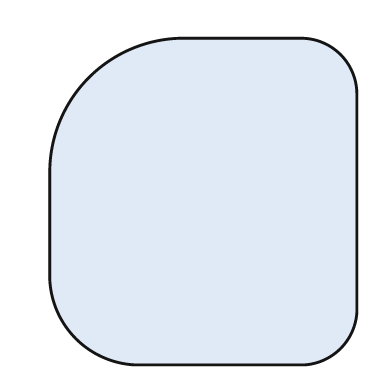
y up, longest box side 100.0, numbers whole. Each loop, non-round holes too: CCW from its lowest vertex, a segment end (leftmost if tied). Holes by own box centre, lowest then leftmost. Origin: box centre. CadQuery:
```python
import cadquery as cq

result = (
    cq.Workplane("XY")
    .moveTo(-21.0, -50.0)
    .lineTo(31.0, -50.0)
    .threePointArc((42.0, -45.0), (47.0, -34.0))
    .lineTo(47.0, 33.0)
    .threePointArc((42.0, 45.0), (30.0, 50.0))
    .lineTo(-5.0, 50.0)
    .threePointArc((-35.0, 38.0), (-47.0, 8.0))
    .lineTo(-47.0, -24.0)
    .threePointArc((-39.0, -42.0), (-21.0, -50.0))
    .close()
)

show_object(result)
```